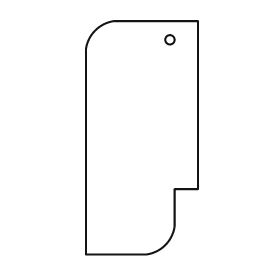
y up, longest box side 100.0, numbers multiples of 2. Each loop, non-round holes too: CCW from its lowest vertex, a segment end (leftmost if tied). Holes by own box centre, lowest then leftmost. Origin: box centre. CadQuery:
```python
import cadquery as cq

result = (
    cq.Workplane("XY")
    .moveTo(-24.0, -50.0)
    .lineTo(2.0, -50.0)
    .threePointArc((10.0, -46.0), (14.0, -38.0))
    .lineTo(14.0, -22.0)
    .lineTo(24.0, -22.0)
    .lineTo(24.0, 50.0)
    .lineTo(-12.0, 50.0)
    .threePointArc((-20.0, 46.0), (-24.0, 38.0))
    .close()
    .moveTo(12.0, 42.0)
    .circle(2.0)
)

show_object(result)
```